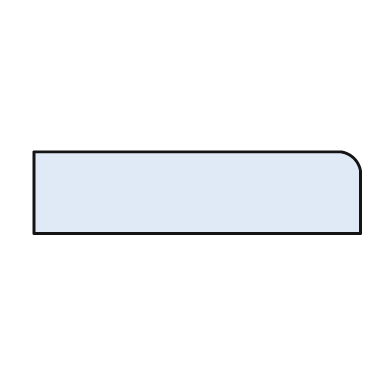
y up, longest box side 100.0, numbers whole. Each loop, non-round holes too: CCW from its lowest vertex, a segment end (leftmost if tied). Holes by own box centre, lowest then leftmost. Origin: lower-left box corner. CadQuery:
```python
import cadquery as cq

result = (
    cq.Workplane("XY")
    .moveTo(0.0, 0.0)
    .lineTo(100.0, 0.0)
    .lineTo(100.0, 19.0)
    .threePointArc((98.0, 23.0), (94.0, 25.0))
    .lineTo(0.0, 25.0)
    .close()
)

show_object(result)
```